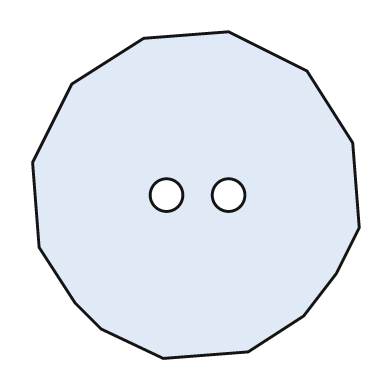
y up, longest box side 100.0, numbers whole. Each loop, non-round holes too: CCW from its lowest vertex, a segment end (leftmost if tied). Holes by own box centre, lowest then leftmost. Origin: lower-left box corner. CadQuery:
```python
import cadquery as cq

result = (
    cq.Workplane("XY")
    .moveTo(40.0, 0.0)
    .lineTo(66.0, 2.0)
    .lineTo(83.0, 13.0)
    .lineTo(93.0, 26.0)
    .lineTo(100.0, 40.0)
    .lineTo(98.0, 66.0)
    .lineTo(84.0, 88.0)
    .lineTo(60.0, 100.0)
    .lineTo(34.0, 98.0)
    .lineTo(12.0, 84.0)
    .lineTo(0.0, 60.0)
    .lineTo(2.0, 34.0)
    .lineTo(13.0, 17.0)
    .lineTo(21.0, 9.0)
    .close()
    .moveTo(41.0, 50.0)
    .circle(5.0)
    .moveTo(60.0, 50.0)
    .circle(5.0)
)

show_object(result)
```